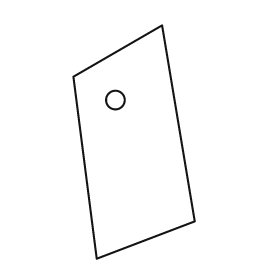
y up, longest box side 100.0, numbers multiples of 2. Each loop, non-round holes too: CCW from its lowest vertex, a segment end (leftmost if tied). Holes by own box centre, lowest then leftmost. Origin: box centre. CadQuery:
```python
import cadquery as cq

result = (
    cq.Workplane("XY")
    .moveTo(-16.0, -50.0)
    .lineTo(26.0, -34.0)
    .lineTo(12.0, 50.0)
    .lineTo(-26.0, 28.0)
    .close()
    .moveTo(-8.0, 18.0)
    .circle(4.0)
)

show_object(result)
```